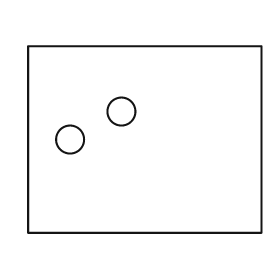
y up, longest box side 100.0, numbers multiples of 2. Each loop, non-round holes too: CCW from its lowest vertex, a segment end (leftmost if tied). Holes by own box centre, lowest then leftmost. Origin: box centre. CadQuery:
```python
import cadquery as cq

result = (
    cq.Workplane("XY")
    .moveTo(-50.0, -40.0)
    .lineTo(50.0, -40.0)
    .lineTo(50.0, 40.0)
    .lineTo(-50.0, 40.0)
    .close()
    .moveTo(-32.0, 0.0)
    .circle(6.0)
    .moveTo(-10.0, 12.0)
    .circle(6.0)
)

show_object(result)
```